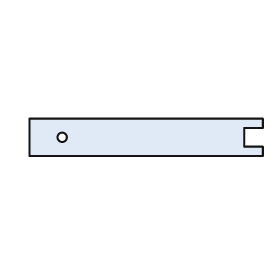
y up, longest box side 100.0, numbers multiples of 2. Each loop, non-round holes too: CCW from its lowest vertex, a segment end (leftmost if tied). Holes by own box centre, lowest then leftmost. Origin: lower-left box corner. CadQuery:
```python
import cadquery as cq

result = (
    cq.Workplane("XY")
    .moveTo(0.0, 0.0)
    .lineTo(100.0, 0.0)
    .lineTo(100.0, 4.0)
    .lineTo(92.0, 4.0)
    .lineTo(92.0, 12.0)
    .lineTo(100.0, 12.0)
    .lineTo(100.0, 16.0)
    .lineTo(0.0, 16.0)
    .close()
    .moveTo(14.0, 8.0)
    .circle(2.0)
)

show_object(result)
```